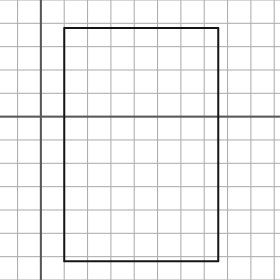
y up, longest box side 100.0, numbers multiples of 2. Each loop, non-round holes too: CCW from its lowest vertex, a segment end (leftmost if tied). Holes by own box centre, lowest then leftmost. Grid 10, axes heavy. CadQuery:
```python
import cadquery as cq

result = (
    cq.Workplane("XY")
    .moveTo(10.0, -62.0)
    .lineTo(76.0, -62.0)
    .lineTo(76.0, 38.0)
    .lineTo(10.0, 38.0)
    .close()
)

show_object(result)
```